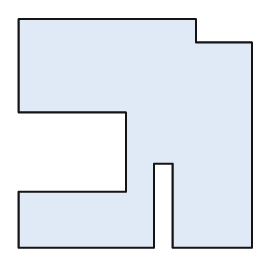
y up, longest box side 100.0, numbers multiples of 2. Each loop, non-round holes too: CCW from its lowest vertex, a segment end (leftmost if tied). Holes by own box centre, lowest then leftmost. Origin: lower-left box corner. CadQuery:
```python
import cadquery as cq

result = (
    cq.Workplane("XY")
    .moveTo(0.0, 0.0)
    .lineTo(58.0, 0.0)
    .lineTo(58.0, 36.0)
    .lineTo(66.0, 36.0)
    .lineTo(66.0, 0.0)
    .lineTo(100.0, 0.0)
    .lineTo(100.0, 88.0)
    .lineTo(76.0, 88.0)
    .lineTo(76.0, 98.0)
    .lineTo(0.0, 98.0)
    .lineTo(0.0, 58.0)
    .lineTo(46.0, 58.0)
    .lineTo(46.0, 24.0)
    .lineTo(0.0, 24.0)
    .close()
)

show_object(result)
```